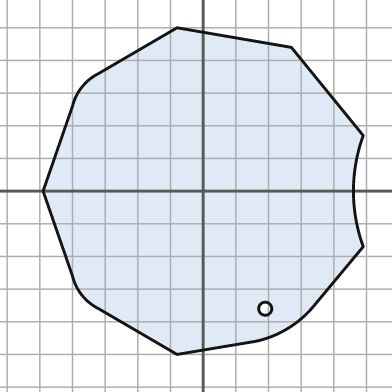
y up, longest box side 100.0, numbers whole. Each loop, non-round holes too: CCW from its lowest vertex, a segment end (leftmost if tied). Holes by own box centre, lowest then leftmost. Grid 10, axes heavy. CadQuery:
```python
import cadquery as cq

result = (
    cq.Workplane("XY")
    .moveTo(-8.0, -50.0)
    .lineTo(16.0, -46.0)
    .threePointArc((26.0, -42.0), (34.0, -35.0))
    .lineTo(49.0, -17.0)
    .threePointArc((46.0, 0.0), (49.0, 17.0))
    .lineTo(27.0, 44.0)
    .lineTo(-8.0, 50.0)
    .lineTo(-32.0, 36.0)
    .threePointArc((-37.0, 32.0), (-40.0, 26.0))
    .lineTo(-49.0, 0.0)
    .lineTo(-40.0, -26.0)
    .threePointArc((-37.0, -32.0), (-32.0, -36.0))
    .close()
    .moveTo(19.0, -36.0)
    .circle(2.0)
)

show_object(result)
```